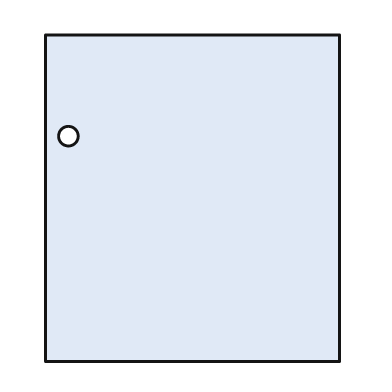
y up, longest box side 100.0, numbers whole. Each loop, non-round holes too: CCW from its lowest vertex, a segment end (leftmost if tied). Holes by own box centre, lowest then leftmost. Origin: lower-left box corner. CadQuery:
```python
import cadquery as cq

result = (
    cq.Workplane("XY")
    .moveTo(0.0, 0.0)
    .lineTo(90.0, 0.0)
    .lineTo(90.0, 100.0)
    .lineTo(0.0, 100.0)
    .close()
    .moveTo(7.0, 69.0)
    .circle(3.0)
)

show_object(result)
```